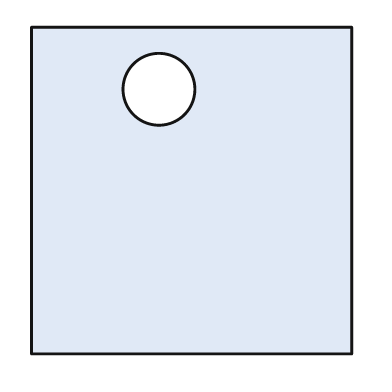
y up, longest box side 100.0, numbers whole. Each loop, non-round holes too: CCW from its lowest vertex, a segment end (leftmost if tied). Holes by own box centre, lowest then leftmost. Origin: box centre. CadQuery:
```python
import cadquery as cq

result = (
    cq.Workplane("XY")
    .moveTo(-49.0, -50.0)
    .lineTo(49.0, -50.0)
    .lineTo(49.0, 50.0)
    .lineTo(-49.0, 50.0)
    .close()
    .moveTo(-10.0, 31.0)
    .circle(11.0)
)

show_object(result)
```